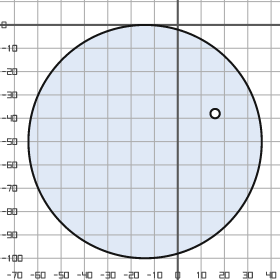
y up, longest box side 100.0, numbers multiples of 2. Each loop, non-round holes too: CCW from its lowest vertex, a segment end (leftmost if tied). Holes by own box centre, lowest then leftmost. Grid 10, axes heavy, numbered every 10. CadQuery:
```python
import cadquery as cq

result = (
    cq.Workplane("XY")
    .moveTo(-14.0, -50.0)
    .circle(50.0)
    .moveTo(16.0, -38.0)
    .circle(2.0)
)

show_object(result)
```